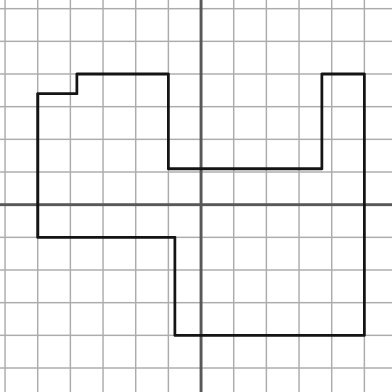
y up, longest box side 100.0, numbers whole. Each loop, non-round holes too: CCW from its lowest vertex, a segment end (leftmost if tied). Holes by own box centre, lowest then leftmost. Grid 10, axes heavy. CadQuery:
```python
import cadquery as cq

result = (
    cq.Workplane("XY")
    .moveTo(-8.0, -40.0)
    .lineTo(50.0, -40.0)
    .lineTo(50.0, 40.0)
    .lineTo(37.0, 40.0)
    .lineTo(37.0, 11.0)
    .lineTo(-10.0, 11.0)
    .lineTo(-10.0, 40.0)
    .lineTo(-38.0, 40.0)
    .lineTo(-38.0, 34.0)
    .lineTo(-50.0, 34.0)
    .lineTo(-50.0, -10.0)
    .lineTo(-8.0, -10.0)
    .close()
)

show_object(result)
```